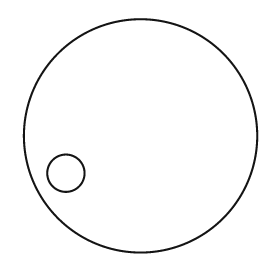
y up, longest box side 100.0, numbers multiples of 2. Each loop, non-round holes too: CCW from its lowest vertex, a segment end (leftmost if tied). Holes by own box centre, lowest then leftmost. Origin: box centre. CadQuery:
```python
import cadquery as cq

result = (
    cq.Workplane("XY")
    .moveTo(0.0, 0.0)
    .circle(50.0)
    .moveTo(-32.0, -16.0)
    .circle(8.0)
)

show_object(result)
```